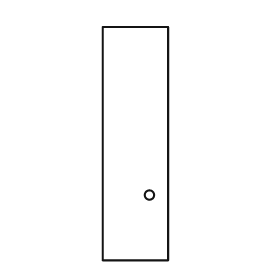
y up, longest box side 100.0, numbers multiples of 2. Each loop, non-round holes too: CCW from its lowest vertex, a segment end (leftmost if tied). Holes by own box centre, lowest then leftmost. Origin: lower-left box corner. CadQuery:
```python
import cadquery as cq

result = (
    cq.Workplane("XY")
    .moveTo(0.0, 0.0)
    .lineTo(28.0, 0.0)
    .lineTo(28.0, 100.0)
    .lineTo(0.0, 100.0)
    .close()
    .moveTo(20.0, 28.0)
    .circle(2.0)
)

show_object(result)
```